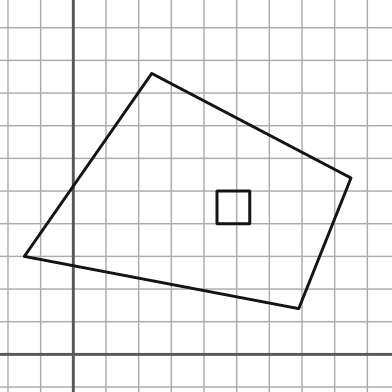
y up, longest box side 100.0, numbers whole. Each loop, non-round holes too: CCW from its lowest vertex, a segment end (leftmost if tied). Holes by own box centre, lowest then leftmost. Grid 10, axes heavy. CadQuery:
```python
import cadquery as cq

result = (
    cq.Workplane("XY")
    .moveTo(69.0, 14.0)
    .lineTo(85.0, 54.0)
    .lineTo(24.0, 86.0)
    .lineTo(-15.0, 30.0)
    .close()
    .moveTo(44.0, 40.0)
    .lineTo(54.0, 40.0)
    .lineTo(54.0, 50.0)
    .lineTo(44.0, 50.0)
    .close()
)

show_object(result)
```